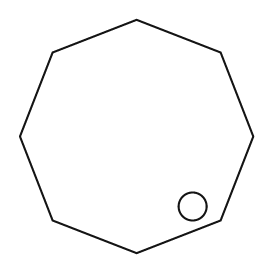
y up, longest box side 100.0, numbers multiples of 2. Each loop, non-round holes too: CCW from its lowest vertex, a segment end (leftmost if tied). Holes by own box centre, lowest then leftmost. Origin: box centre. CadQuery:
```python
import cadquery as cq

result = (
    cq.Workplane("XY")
    .moveTo(0.0, -50.0)
    .lineTo(36.0, -36.0)
    .lineTo(50.0, 0.0)
    .lineTo(36.0, 36.0)
    .lineTo(0.0, 50.0)
    .lineTo(-36.0, 36.0)
    .lineTo(-50.0, 0.0)
    .lineTo(-36.0, -36.0)
    .close()
    .moveTo(24.0, -30.0)
    .circle(6.0)
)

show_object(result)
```